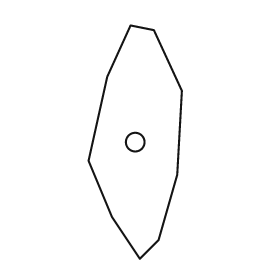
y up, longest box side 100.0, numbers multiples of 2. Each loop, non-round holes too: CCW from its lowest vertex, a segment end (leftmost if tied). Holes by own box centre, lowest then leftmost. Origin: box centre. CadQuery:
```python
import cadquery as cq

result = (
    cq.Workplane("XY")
    .moveTo(2.0, -50.0)
    .lineTo(10.0, -42.0)
    .lineTo(18.0, -14.0)
    .lineTo(20.0, 22.0)
    .lineTo(8.0, 48.0)
    .lineTo(-2.0, 50.0)
    .lineTo(-12.0, 28.0)
    .lineTo(-20.0, -8.0)
    .lineTo(-10.0, -32.0)
    .close()
    .moveTo(0.0, 0.0)
    .circle(4.0)
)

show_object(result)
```